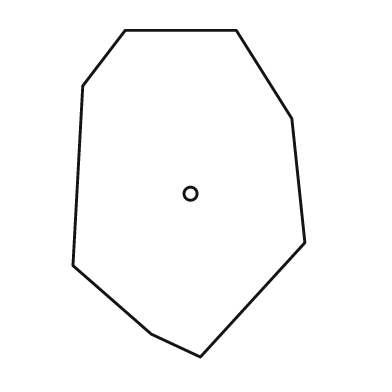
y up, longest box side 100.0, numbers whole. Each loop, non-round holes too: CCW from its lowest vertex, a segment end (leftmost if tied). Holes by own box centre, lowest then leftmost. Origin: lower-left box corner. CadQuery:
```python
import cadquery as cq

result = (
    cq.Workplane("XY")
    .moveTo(39.0, 0.0)
    .lineTo(71.0, 35.0)
    .lineTo(67.0, 73.0)
    .lineTo(50.0, 100.0)
    .lineTo(16.0, 100.0)
    .lineTo(3.0, 83.0)
    .lineTo(0.0, 28.0)
    .lineTo(24.0, 7.0)
    .close()
    .moveTo(36.0, 50.0)
    .circle(2.0)
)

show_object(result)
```